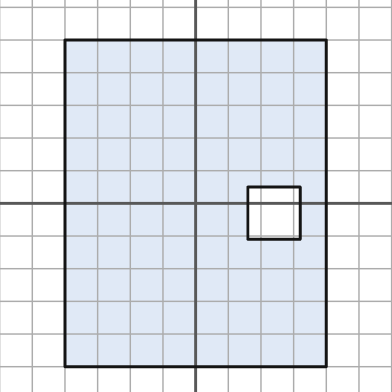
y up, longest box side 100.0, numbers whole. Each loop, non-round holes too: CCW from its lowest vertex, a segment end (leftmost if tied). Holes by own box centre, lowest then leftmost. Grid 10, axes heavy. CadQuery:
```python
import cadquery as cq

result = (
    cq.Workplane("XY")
    .moveTo(-40.0, -50.0)
    .lineTo(40.0, -50.0)
    .lineTo(40.0, 50.0)
    .lineTo(-40.0, 50.0)
    .close()
    .moveTo(16.0, -11.0)
    .lineTo(32.0, -11.0)
    .lineTo(32.0, 5.0)
    .lineTo(16.0, 5.0)
    .close()
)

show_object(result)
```